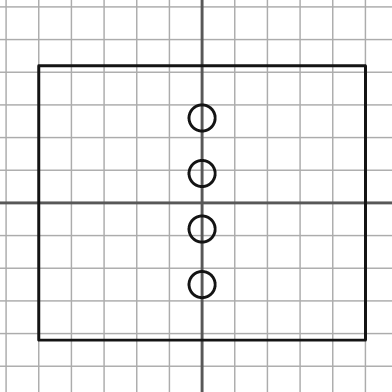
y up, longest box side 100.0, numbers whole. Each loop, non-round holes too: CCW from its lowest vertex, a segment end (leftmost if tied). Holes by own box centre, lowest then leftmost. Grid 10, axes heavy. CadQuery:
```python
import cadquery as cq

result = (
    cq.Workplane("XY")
    .moveTo(-50.0, -42.0)
    .lineTo(50.0, -42.0)
    .lineTo(50.0, 42.0)
    .lineTo(-50.0, 42.0)
    .close()
    .moveTo(0.0, -25.0)
    .circle(4.0)
    .moveTo(0.0, -8.0)
    .circle(4.0)
    .moveTo(0.0, 9.0)
    .circle(4.0)
    .moveTo(0.0, 26.0)
    .circle(4.0)
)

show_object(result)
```